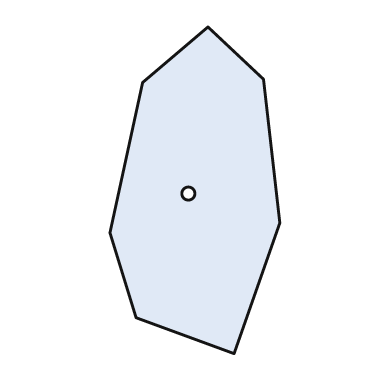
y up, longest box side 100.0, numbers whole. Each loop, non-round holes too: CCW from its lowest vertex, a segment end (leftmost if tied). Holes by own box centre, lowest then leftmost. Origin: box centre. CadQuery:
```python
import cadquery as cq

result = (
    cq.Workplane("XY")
    .moveTo(12.0, -50.0)
    .lineTo(26.0, -10.0)
    .lineTo(21.0, 34.0)
    .lineTo(4.0, 50.0)
    .lineTo(-16.0, 33.0)
    .lineTo(-26.0, -13.0)
    .lineTo(-18.0, -39.0)
    .close()
    .moveTo(-2.0, -1.0)
    .circle(2.0)
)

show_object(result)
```